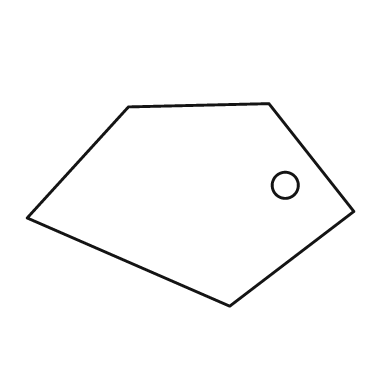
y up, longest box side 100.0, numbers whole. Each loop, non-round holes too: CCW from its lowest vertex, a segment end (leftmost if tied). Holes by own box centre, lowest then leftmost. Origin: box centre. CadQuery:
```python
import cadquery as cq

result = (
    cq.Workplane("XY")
    .moveTo(12.0, -31.0)
    .lineTo(50.0, -2.0)
    .lineTo(24.0, 31.0)
    .lineTo(-19.0, 30.0)
    .lineTo(-50.0, -4.0)
    .close()
    .moveTo(29.0, 6.0)
    .circle(4.0)
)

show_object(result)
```